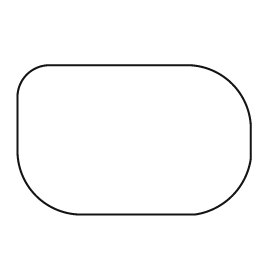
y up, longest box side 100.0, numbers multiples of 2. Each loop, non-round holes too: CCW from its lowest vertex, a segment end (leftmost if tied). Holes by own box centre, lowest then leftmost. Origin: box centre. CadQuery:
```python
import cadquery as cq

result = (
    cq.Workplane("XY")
    .moveTo(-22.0, -32.0)
    .lineTo(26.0, -32.0)
    .threePointArc((42.0, -24.0), (50.0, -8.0))
    .lineTo(50.0, 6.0)
    .threePointArc((42.0, 24.0), (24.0, 32.0))
    .lineTo(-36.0, 32.0)
    .threePointArc((-46.0, 28.0), (-50.0, 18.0))
    .lineTo(-50.0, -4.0)
    .threePointArc((-42.0, -24.0), (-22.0, -32.0))
    .close()
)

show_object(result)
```